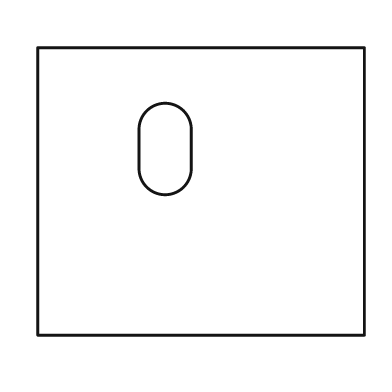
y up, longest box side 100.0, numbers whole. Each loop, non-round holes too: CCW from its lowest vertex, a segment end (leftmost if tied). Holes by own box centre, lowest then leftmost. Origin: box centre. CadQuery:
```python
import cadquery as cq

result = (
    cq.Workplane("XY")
    .moveTo(-50.0, -44.0)
    .lineTo(50.0, -44.0)
    .lineTo(50.0, 44.0)
    .lineTo(-50.0, 44.0)
    .close()
    .moveTo(-19.0, 7.0)
    .threePointArc((-11.0, -1.0), (-3.0, 7.0))
    .lineTo(-3.0, 19.0)
    .threePointArc((-11.0, 27.0), (-19.0, 19.0))
    .close()
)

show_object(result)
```